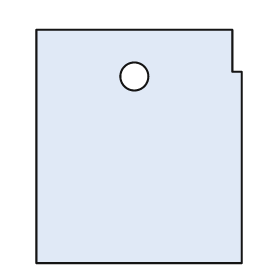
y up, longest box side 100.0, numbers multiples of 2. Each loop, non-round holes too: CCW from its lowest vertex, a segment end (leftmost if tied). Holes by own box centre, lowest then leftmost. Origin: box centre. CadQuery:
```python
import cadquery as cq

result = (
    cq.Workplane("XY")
    .moveTo(-44.0, -50.0)
    .lineTo(44.0, -50.0)
    .lineTo(44.0, 32.0)
    .lineTo(40.0, 32.0)
    .lineTo(40.0, 50.0)
    .lineTo(-44.0, 50.0)
    .close()
    .moveTo(-2.0, 30.0)
    .circle(6.0)
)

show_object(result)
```